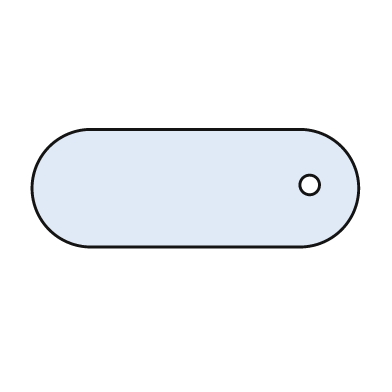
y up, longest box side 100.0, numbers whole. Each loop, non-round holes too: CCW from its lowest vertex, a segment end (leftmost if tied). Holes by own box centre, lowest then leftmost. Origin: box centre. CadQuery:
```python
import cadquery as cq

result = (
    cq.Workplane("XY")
    .moveTo(-32.0, -18.0)
    .lineTo(32.0, -18.0)
    .threePointArc((50.0, 0.0), (32.0, 18.0))
    .lineTo(-32.0, 18.0)
    .threePointArc((-50.0, 0.0), (-32.0, -18.0))
    .close()
    .moveTo(35.0, 1.0)
    .circle(3.0)
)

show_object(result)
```